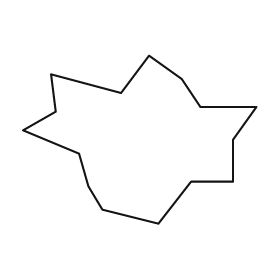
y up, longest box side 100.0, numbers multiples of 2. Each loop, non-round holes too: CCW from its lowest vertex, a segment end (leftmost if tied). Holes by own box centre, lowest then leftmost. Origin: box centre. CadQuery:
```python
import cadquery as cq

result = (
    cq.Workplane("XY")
    .moveTo(8.0, -36.0)
    .lineTo(22.0, -18.0)
    .lineTo(40.0, -18.0)
    .lineTo(40.0, 0.0)
    .lineTo(50.0, 14.0)
    .lineTo(26.0, 14.0)
    .lineTo(18.0, 26.0)
    .lineTo(4.0, 36.0)
    .lineTo(-8.0, 20.0)
    .lineTo(-38.0, 28.0)
    .lineTo(-36.0, 12.0)
    .lineTo(-50.0, 4.0)
    .lineTo(-26.0, -6.0)
    .lineTo(-22.0, -20.0)
    .lineTo(-16.0, -30.0)
    .close()
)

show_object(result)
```